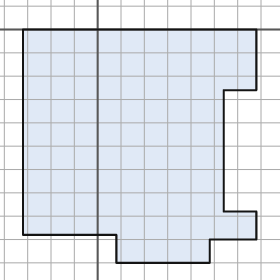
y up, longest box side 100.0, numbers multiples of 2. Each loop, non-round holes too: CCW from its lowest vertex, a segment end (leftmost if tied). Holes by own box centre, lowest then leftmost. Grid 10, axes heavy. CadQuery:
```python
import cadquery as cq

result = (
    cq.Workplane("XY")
    .moveTo(8.0, -100.0)
    .lineTo(48.0, -100.0)
    .lineTo(48.0, -90.0)
    .lineTo(68.0, -90.0)
    .lineTo(68.0, -78.0)
    .lineTo(54.0, -78.0)
    .lineTo(54.0, -26.0)
    .lineTo(68.0, -26.0)
    .lineTo(68.0, 0.0)
    .lineTo(-32.0, 0.0)
    .lineTo(-32.0, -88.0)
    .lineTo(8.0, -88.0)
    .close()
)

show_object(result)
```